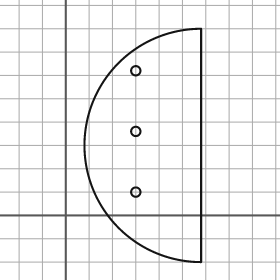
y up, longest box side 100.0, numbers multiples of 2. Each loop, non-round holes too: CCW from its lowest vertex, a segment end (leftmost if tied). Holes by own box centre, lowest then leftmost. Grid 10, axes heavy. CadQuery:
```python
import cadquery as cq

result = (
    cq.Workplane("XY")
    .moveTo(58.0, -20.0)
    .lineTo(58.0, 80.0)
    .threePointArc((8.0, 30.0), (58.0, -20.0))
    .close()
    .moveTo(30.0, 10.0)
    .circle(2.0)
    .moveTo(30.0, 36.0)
    .circle(2.0)
    .moveTo(30.0, 62.0)
    .circle(2.0)
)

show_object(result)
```